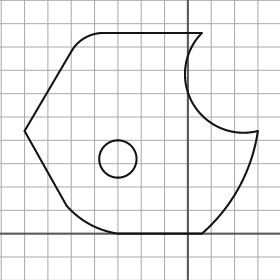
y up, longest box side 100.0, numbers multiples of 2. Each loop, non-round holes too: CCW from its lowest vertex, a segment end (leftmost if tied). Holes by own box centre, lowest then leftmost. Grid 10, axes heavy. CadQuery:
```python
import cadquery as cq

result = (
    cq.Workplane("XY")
    .moveTo(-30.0, 0.0)
    .lineTo(6.0, 0.0)
    .threePointArc((22.0, 20.0), (30.0, 44.0))
    .threePointArc((2.0, 56.0), (6.0, 86.0))
    .lineTo(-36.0, 86.0)
    .threePointArc((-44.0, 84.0), (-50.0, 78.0))
    .lineTo(-70.0, 44.0)
    .lineTo(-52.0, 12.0)
    .threePointArc((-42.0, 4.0), (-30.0, 0.0))
    .close()
    .moveTo(-30.0, 32.0)
    .circle(8.0)
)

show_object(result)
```